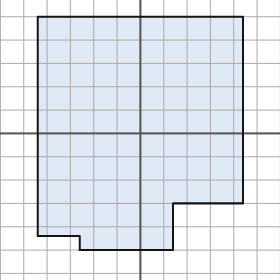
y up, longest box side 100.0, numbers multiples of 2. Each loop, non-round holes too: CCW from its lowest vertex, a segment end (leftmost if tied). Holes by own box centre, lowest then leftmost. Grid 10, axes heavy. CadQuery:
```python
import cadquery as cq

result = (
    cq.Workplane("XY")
    .moveTo(-26.0, -50.0)
    .lineTo(14.0, -50.0)
    .lineTo(14.0, -30.0)
    .lineTo(44.0, -30.0)
    .lineTo(44.0, 50.0)
    .lineTo(-44.0, 50.0)
    .lineTo(-44.0, -44.0)
    .lineTo(-26.0, -44.0)
    .close()
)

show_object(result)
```